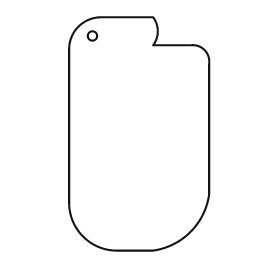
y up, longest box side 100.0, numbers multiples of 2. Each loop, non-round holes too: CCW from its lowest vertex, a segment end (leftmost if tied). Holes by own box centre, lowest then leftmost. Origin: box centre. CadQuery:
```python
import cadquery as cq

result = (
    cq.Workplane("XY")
    .moveTo(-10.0, -50.0)
    .lineTo(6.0, -50.0)
    .threePointArc((22.0, -42.0), (30.0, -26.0))
    .lineTo(30.0, 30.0)
    .threePointArc((28.0, 36.0), (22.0, 38.0))
    .lineTo(6.0, 38.0)
    .threePointArc((8.0, 44.0), (6.0, 50.0))
    .lineTo(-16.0, 50.0)
    .threePointArc((-26.0, 46.0), (-30.0, 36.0))
    .lineTo(-30.0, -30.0)
    .threePointArc((-24.0, -44.0), (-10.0, -50.0))
    .close()
    .moveTo(-20.0, 42.0)
    .circle(2.0)
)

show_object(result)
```